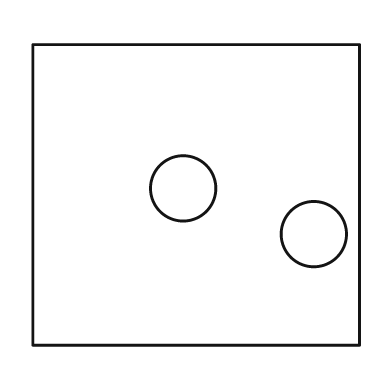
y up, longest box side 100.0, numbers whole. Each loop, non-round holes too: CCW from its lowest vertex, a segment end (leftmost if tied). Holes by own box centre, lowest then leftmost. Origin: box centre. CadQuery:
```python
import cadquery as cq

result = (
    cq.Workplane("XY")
    .moveTo(-50.0, -46.0)
    .lineTo(50.0, -46.0)
    .lineTo(50.0, 46.0)
    .lineTo(-50.0, 46.0)
    .close()
    .moveTo(36.0, -12.0)
    .circle(10.0)
    .moveTo(-4.0, 2.0)
    .circle(10.0)
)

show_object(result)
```